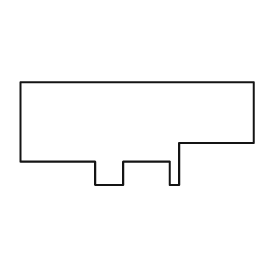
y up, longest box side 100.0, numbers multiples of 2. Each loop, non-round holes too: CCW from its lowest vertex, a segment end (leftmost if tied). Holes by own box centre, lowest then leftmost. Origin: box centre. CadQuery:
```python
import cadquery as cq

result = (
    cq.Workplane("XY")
    .moveTo(-18.0, -22.0)
    .lineTo(-6.0, -22.0)
    .lineTo(-6.0, -12.0)
    .lineTo(14.0, -12.0)
    .lineTo(14.0, -22.0)
    .lineTo(18.0, -22.0)
    .lineTo(18.0, -4.0)
    .lineTo(50.0, -4.0)
    .lineTo(50.0, 22.0)
    .lineTo(-50.0, 22.0)
    .lineTo(-50.0, -12.0)
    .lineTo(-18.0, -12.0)
    .close()
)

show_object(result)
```